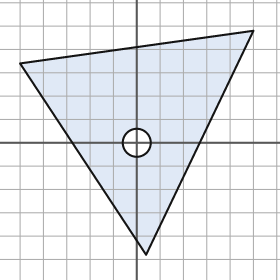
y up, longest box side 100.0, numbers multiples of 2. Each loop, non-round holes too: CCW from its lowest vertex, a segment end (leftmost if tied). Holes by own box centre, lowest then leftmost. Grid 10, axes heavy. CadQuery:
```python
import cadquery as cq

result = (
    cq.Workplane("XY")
    .moveTo(4.0, -48.0)
    .lineTo(50.0, 48.0)
    .lineTo(-50.0, 34.0)
    .close()
    .moveTo(0.0, 0.0)
    .circle(6.0)
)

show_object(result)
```